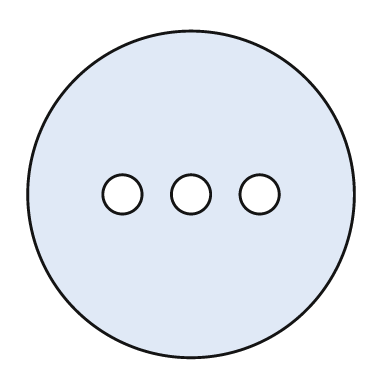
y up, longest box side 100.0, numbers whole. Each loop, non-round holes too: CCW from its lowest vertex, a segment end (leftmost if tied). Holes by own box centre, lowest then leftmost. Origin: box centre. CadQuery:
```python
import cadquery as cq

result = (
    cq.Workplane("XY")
    .moveTo(0.0, 0.0)
    .circle(50.0)
    .moveTo(-21.0, 0.0)
    .circle(6.0)
    .moveTo(0.0, 0.0)
    .circle(6.0)
    .moveTo(21.0, 0.0)
    .circle(6.0)
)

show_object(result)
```